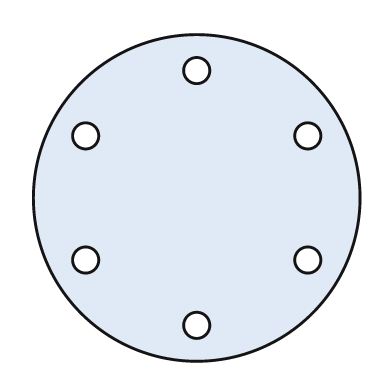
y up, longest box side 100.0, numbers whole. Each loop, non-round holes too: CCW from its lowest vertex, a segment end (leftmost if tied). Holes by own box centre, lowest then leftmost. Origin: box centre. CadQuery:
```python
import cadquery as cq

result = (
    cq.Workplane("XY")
    .moveTo(0.0, 0.0)
    .circle(50.0)
    .moveTo(0.0, -39.0)
    .circle(4.0)
    .moveTo(-34.0, -19.0)
    .circle(4.0)
    .moveTo(34.0, -19.0)
    .circle(4.0)
    .moveTo(-34.0, 19.0)
    .circle(4.0)
    .moveTo(34.0, 19.0)
    .circle(4.0)
    .moveTo(0.0, 39.0)
    .circle(4.0)
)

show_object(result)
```